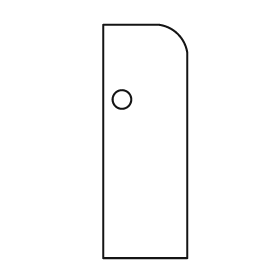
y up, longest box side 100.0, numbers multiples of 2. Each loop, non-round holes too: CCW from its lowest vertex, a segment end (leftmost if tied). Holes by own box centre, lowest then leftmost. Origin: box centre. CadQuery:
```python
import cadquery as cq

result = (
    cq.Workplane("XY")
    .moveTo(-18.0, -50.0)
    .lineTo(18.0, -50.0)
    .lineTo(18.0, 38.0)
    .threePointArc((14.0, 46.0), (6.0, 50.0))
    .lineTo(-18.0, 50.0)
    .close()
    .moveTo(-10.0, 18.0)
    .circle(4.0)
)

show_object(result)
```